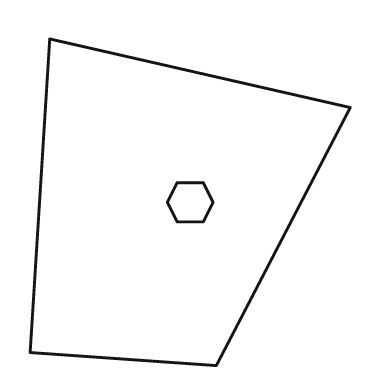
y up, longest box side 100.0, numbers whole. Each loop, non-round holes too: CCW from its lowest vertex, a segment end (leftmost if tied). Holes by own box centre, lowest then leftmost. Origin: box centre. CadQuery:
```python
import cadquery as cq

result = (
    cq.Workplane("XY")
    .moveTo(8.0, -50.0)
    .lineTo(49.0, 29.0)
    .lineTo(-43.0, 50.0)
    .lineTo(-49.0, -46.0)
    .close()
    .moveTo(-4.0, -6.0)
    .lineTo(4.0, -6.0)
    .lineTo(7.0, 0.0)
    .lineTo(4.0, 6.0)
    .lineTo(-4.0, 6.0)
    .lineTo(-7.0, 0.0)
    .close()
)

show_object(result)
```